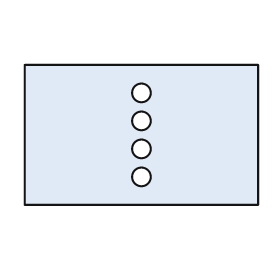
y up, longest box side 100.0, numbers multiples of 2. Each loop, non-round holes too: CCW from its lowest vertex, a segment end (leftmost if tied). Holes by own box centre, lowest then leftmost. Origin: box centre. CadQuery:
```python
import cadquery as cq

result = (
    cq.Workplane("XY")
    .moveTo(-50.0, -30.0)
    .lineTo(50.0, -30.0)
    .lineTo(50.0, 30.0)
    .lineTo(-50.0, 30.0)
    .close()
    .moveTo(0.0, -18.0)
    .circle(4.0)
    .moveTo(0.0, -6.0)
    .circle(4.0)
    .moveTo(0.0, 6.0)
    .circle(4.0)
    .moveTo(0.0, 18.0)
    .circle(4.0)
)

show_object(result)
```